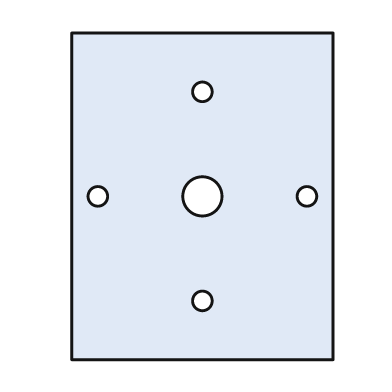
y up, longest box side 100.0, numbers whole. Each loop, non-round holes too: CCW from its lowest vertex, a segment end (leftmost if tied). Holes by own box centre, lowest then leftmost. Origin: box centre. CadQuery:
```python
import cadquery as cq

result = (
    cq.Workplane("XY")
    .moveTo(-40.0, -50.0)
    .lineTo(40.0, -50.0)
    .lineTo(40.0, 50.0)
    .lineTo(-40.0, 50.0)
    .close()
    .moveTo(0.0, -32.0)
    .circle(3.0)
    .moveTo(-32.0, 0.0)
    .circle(3.0)
    .moveTo(0.0, 0.0)
    .circle(6.0)
    .moveTo(32.0, 0.0)
    .circle(3.0)
    .moveTo(0.0, 32.0)
    .circle(3.0)
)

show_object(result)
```